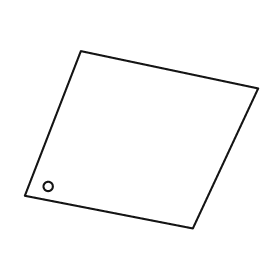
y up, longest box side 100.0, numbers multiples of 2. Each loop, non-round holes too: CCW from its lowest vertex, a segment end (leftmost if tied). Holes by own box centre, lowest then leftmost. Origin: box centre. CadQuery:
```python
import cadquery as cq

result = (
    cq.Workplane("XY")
    .moveTo(22.0, -38.0)
    .lineTo(50.0, 22.0)
    .lineTo(-26.0, 38.0)
    .lineTo(-50.0, -24.0)
    .close()
    .moveTo(-40.0, -20.0)
    .circle(2.0)
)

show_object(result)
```